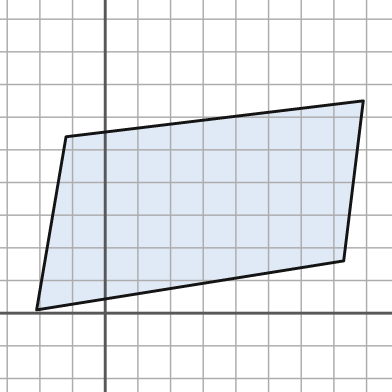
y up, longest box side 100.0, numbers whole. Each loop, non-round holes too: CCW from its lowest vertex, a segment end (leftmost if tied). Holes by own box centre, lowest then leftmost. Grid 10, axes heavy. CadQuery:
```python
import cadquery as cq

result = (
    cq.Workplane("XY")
    .moveTo(-21.0, 1.0)
    .lineTo(73.0, 16.0)
    .lineTo(79.0, 65.0)
    .lineTo(-12.0, 54.0)
    .close()
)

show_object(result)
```